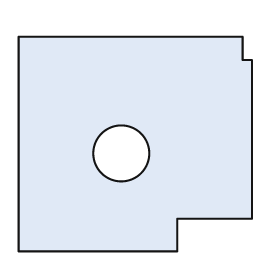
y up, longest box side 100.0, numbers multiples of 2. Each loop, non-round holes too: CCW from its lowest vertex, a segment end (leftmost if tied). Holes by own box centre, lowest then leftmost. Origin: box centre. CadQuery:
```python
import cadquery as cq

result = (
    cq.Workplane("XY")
    .moveTo(-50.0, -46.0)
    .lineTo(18.0, -46.0)
    .lineTo(18.0, -32.0)
    .lineTo(50.0, -32.0)
    .lineTo(50.0, 36.0)
    .lineTo(46.0, 36.0)
    .lineTo(46.0, 46.0)
    .lineTo(-50.0, 46.0)
    .close()
    .moveTo(-6.0, -4.0)
    .circle(12.0)
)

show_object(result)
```